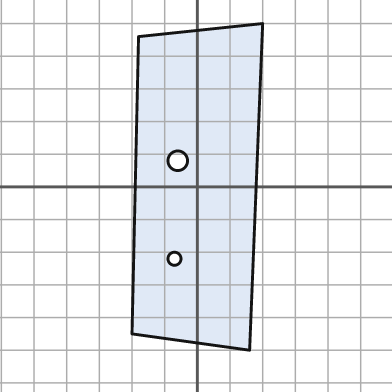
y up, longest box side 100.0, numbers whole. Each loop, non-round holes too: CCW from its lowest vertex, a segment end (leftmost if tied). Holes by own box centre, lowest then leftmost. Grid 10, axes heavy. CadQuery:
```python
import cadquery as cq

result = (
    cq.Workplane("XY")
    .moveTo(16.0, -50.0)
    .lineTo(20.0, 50.0)
    .lineTo(-18.0, 46.0)
    .lineTo(-20.0, -45.0)
    .close()
    .moveTo(-7.0, -22.0)
    .circle(2.0)
    .moveTo(-6.0, 8.0)
    .circle(3.0)
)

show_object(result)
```